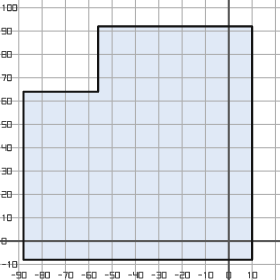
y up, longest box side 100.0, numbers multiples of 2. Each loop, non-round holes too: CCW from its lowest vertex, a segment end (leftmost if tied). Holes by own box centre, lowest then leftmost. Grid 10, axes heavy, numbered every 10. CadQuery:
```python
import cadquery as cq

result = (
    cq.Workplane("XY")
    .moveTo(-88.0, -8.0)
    .lineTo(10.0, -8.0)
    .lineTo(10.0, 92.0)
    .lineTo(-56.0, 92.0)
    .lineTo(-56.0, 64.0)
    .lineTo(-88.0, 64.0)
    .close()
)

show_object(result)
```